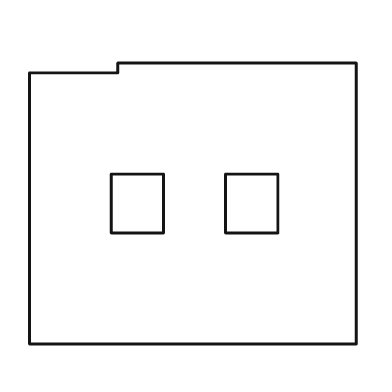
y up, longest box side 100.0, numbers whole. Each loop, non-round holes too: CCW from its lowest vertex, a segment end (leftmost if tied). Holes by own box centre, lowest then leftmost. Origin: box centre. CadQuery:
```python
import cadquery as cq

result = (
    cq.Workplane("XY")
    .moveTo(-50.0, -43.0)
    .lineTo(50.0, -43.0)
    .lineTo(50.0, 43.0)
    .lineTo(-23.0, 43.0)
    .lineTo(-23.0, 40.0)
    .lineTo(-50.0, 40.0)
    .close()
    .moveTo(-25.0, -9.0)
    .lineTo(-9.0, -9.0)
    .lineTo(-9.0, 9.0)
    .lineTo(-25.0, 9.0)
    .close()
    .moveTo(10.0, -9.0)
    .lineTo(26.0, -9.0)
    .lineTo(26.0, 9.0)
    .lineTo(10.0, 9.0)
    .close()
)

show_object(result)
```